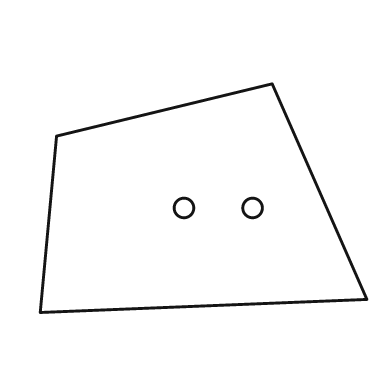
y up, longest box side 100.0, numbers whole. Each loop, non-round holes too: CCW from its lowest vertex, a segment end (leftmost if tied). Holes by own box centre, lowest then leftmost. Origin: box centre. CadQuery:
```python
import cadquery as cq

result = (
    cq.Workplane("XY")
    .moveTo(-50.0, -35.0)
    .lineTo(50.0, -31.0)
    .lineTo(21.0, 35.0)
    .lineTo(-45.0, 19.0)
    .close()
    .moveTo(-6.0, -3.0)
    .circle(3.0)
    .moveTo(15.0, -3.0)
    .circle(3.0)
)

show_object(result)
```